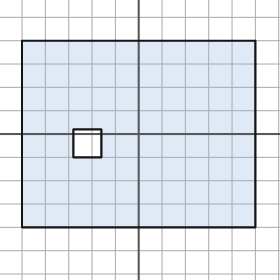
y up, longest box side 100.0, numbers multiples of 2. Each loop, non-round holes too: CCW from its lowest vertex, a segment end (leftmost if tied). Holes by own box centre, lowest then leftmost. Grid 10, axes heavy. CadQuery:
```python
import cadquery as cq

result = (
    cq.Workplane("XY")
    .moveTo(-50.0, -40.0)
    .lineTo(50.0, -40.0)
    .lineTo(50.0, 40.0)
    .lineTo(-50.0, 40.0)
    .close()
    .moveTo(-28.0, -10.0)
    .lineTo(-16.0, -10.0)
    .lineTo(-16.0, 2.0)
    .lineTo(-28.0, 2.0)
    .close()
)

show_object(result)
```